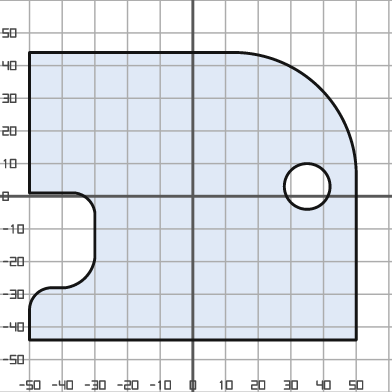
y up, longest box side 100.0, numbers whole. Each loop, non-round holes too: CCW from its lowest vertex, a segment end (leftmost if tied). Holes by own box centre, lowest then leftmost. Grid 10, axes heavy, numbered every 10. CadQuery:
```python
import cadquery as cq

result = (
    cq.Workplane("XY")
    .moveTo(-50.0, -44.0)
    .lineTo(50.0, -44.0)
    .lineTo(50.0, 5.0)
    .threePointArc((39.0, 33.0), (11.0, 44.0))
    .lineTo(-50.0, 44.0)
    .lineTo(-50.0, 1.0)
    .lineTo(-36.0, 1.0)
    .threePointArc((-32.0, -1.0), (-30.0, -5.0))
    .lineTo(-30.0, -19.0)
    .threePointArc((-33.0, -25.0), (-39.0, -28.0))
    .lineTo(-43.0, -28.0)
    .threePointArc((-48.0, -30.0), (-50.0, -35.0))
    .close()
    .moveTo(35.0, 3.0)
    .circle(7.0)
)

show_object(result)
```